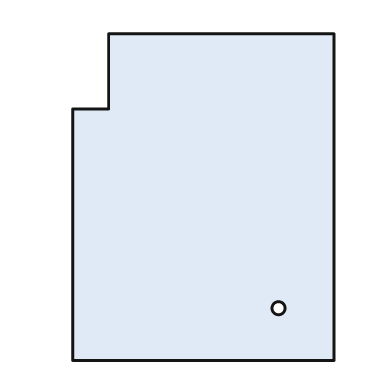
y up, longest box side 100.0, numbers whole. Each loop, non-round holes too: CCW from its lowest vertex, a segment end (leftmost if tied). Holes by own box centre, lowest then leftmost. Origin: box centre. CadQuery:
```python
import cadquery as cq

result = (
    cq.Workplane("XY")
    .moveTo(-40.0, -50.0)
    .lineTo(40.0, -50.0)
    .lineTo(40.0, 50.0)
    .lineTo(-29.0, 50.0)
    .lineTo(-29.0, 27.0)
    .lineTo(-40.0, 27.0)
    .close()
    .moveTo(23.0, -34.0)
    .circle(2.0)
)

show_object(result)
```